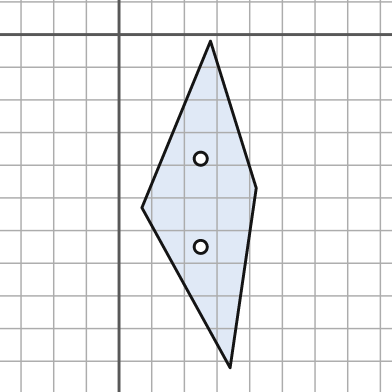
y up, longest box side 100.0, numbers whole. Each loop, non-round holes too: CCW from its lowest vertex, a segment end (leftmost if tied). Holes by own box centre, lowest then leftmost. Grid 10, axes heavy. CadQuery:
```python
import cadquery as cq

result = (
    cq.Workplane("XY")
    .moveTo(34.0, -102.0)
    .lineTo(42.0, -47.0)
    .lineTo(28.0, -2.0)
    .lineTo(7.0, -53.0)
    .close()
    .moveTo(25.0, -65.0)
    .circle(2.0)
    .moveTo(25.0, -38.0)
    .circle(2.0)
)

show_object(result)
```